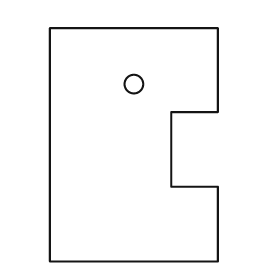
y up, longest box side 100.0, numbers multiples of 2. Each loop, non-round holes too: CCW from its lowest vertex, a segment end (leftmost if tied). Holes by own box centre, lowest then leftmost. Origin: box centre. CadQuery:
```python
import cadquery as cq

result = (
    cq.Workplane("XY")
    .moveTo(-36.0, -50.0)
    .lineTo(36.0, -50.0)
    .lineTo(36.0, -18.0)
    .lineTo(16.0, -18.0)
    .lineTo(16.0, 14.0)
    .lineTo(36.0, 14.0)
    .lineTo(36.0, 50.0)
    .lineTo(-36.0, 50.0)
    .close()
    .moveTo(0.0, 26.0)
    .circle(4.0)
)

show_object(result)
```